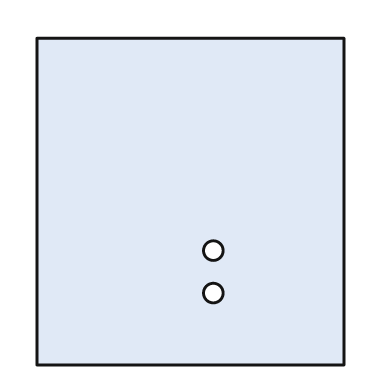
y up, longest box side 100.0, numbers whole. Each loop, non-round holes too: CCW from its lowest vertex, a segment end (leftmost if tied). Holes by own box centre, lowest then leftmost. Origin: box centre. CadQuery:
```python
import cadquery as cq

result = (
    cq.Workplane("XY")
    .moveTo(-47.0, -50.0)
    .lineTo(47.0, -50.0)
    .lineTo(47.0, 50.0)
    .lineTo(-47.0, 50.0)
    .close()
    .moveTo(7.0, -28.0)
    .circle(3.0)
    .moveTo(7.0, -15.0)
    .circle(3.0)
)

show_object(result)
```